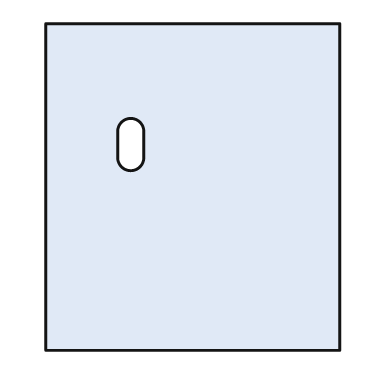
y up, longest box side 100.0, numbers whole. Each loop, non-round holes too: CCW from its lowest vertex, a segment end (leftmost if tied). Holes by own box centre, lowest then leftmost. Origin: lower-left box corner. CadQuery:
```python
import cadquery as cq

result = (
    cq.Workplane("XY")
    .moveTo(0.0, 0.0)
    .lineTo(90.0, 0.0)
    .lineTo(90.0, 100.0)
    .lineTo(0.0, 100.0)
    .close()
    .moveTo(22.0, 59.0)
    .threePointArc((26.0, 55.0), (30.0, 59.0))
    .lineTo(30.0, 67.0)
    .threePointArc((26.0, 71.0), (22.0, 67.0))
    .close()
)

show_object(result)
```